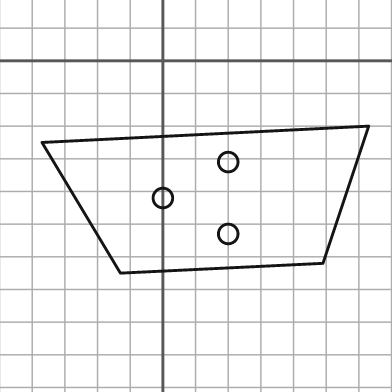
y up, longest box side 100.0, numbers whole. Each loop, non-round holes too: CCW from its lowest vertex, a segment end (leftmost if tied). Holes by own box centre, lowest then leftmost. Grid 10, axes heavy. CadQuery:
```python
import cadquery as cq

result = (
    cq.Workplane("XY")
    .moveTo(-13.0, -65.0)
    .lineTo(49.0, -62.0)
    .lineTo(63.0, -20.0)
    .lineTo(-37.0, -25.0)
    .close()
    .moveTo(20.0, -53.0)
    .circle(3.0)
    .moveTo(0.0, -42.0)
    .circle(3.0)
    .moveTo(20.0, -31.0)
    .circle(3.0)
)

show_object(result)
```